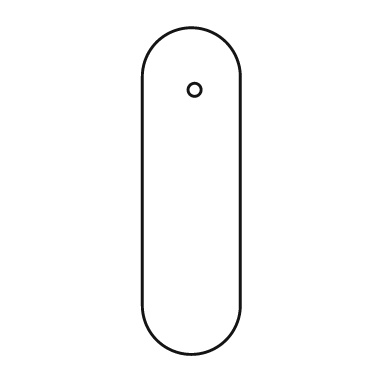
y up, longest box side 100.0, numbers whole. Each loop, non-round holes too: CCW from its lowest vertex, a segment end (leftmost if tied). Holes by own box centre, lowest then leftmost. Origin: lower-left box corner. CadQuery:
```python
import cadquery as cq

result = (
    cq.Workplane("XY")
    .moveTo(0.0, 15.0)
    .threePointArc((15.0, 0.0), (30.0, 15.0))
    .lineTo(30.0, 85.0)
    .threePointArc((15.0, 100.0), (0.0, 85.0))
    .close()
    .moveTo(16.0, 81.0)
    .circle(2.0)
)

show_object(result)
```